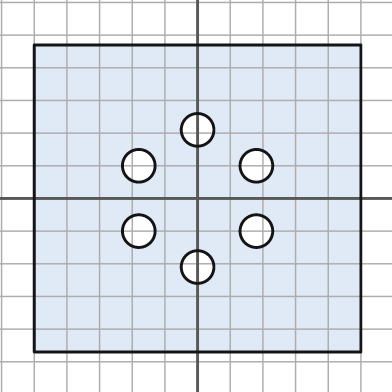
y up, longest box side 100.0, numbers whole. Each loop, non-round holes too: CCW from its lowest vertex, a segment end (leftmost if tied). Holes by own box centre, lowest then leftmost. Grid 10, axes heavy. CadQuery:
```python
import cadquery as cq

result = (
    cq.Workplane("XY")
    .moveTo(-50.0, -47.0)
    .lineTo(50.0, -47.0)
    .lineTo(50.0, 47.0)
    .lineTo(-50.0, 47.0)
    .close()
    .moveTo(0.0, -21.0)
    .circle(5.0)
    .moveTo(-18.0, -10.0)
    .circle(5.0)
    .moveTo(18.0, -10.0)
    .circle(5.0)
    .moveTo(-18.0, 10.0)
    .circle(5.0)
    .moveTo(18.0, 10.0)
    .circle(5.0)
    .moveTo(0.0, 21.0)
    .circle(5.0)
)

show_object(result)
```